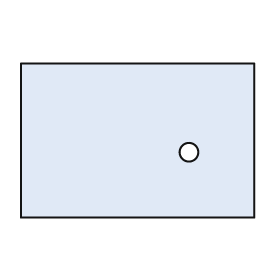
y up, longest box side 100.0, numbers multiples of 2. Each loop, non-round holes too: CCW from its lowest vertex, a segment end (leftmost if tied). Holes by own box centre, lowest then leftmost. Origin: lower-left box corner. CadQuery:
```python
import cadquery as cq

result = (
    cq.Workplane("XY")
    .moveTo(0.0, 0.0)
    .lineTo(100.0, 0.0)
    .lineTo(100.0, 66.0)
    .lineTo(0.0, 66.0)
    .close()
    .moveTo(72.0, 28.0)
    .circle(4.0)
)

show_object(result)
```